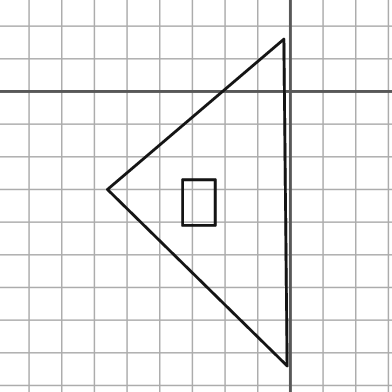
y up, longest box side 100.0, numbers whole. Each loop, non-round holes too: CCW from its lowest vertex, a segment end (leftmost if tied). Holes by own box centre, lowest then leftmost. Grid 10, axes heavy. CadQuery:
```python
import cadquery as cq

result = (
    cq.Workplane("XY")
    .moveTo(-1.0, -84.0)
    .lineTo(-2.0, 16.0)
    .lineTo(-56.0, -30.0)
    .close()
    .moveTo(-33.0, -41.0)
    .lineTo(-23.0, -41.0)
    .lineTo(-23.0, -27.0)
    .lineTo(-33.0, -27.0)
    .close()
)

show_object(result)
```